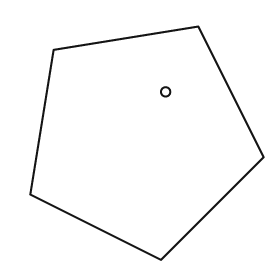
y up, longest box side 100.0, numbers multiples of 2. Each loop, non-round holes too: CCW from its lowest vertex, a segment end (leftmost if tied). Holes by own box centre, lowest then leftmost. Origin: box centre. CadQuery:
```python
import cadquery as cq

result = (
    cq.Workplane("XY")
    .moveTo(6.0, -50.0)
    .lineTo(50.0, -6.0)
    .lineTo(22.0, 50.0)
    .lineTo(-40.0, 40.0)
    .lineTo(-50.0, -22.0)
    .close()
    .moveTo(8.0, 22.0)
    .circle(2.0)
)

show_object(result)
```